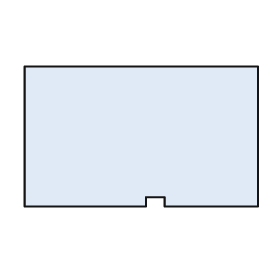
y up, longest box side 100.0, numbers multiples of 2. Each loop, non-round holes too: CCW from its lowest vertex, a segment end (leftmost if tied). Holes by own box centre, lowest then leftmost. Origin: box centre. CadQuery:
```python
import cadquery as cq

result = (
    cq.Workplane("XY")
    .moveTo(-50.0, -30.0)
    .lineTo(2.0, -30.0)
    .lineTo(2.0, -26.0)
    .lineTo(10.0, -26.0)
    .lineTo(10.0, -30.0)
    .lineTo(50.0, -30.0)
    .lineTo(50.0, 30.0)
    .lineTo(-50.0, 30.0)
    .close()
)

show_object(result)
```